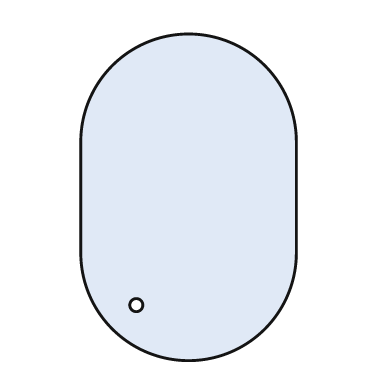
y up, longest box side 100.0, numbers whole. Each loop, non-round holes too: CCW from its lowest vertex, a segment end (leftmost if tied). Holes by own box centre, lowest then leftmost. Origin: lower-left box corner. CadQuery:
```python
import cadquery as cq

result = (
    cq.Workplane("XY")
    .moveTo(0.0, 33.0)
    .threePointArc((33.0, 0.0), (66.0, 33.0))
    .lineTo(66.0, 67.0)
    .threePointArc((33.0, 100.0), (0.0, 67.0))
    .close()
    .moveTo(17.0, 17.0)
    .circle(2.0)
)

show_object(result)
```